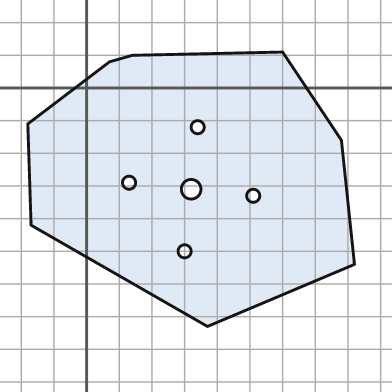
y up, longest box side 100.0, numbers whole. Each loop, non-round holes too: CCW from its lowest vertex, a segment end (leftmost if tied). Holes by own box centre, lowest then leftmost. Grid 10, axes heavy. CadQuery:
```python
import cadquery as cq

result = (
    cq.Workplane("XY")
    .moveTo(37.0, -73.0)
    .lineTo(82.0, -54.0)
    .lineTo(78.0, -16.0)
    .lineTo(60.0, 11.0)
    .lineTo(14.0, 10.0)
    .lineTo(7.0, 8.0)
    .lineTo(-18.0, -11.0)
    .lineTo(-17.0, -42.0)
    .close()
    .moveTo(30.0, -50.0)
    .circle(2.0)
    .moveTo(51.0, -33.0)
    .circle(2.0)
    .moveTo(32.0, -31.0)
    .circle(3.0)
    .moveTo(13.0, -29.0)
    .circle(2.0)
    .moveTo(34.0, -12.0)
    .circle(2.0)
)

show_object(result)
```